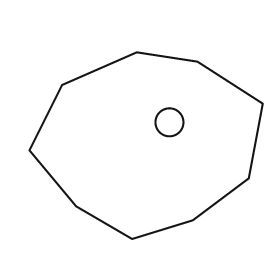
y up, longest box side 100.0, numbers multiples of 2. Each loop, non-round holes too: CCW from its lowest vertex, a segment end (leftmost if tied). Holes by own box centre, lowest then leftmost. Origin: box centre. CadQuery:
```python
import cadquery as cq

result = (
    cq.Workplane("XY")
    .moveTo(-6.0, -40.0)
    .lineTo(20.0, -32.0)
    .lineTo(44.0, -14.0)
    .lineTo(50.0, 18.0)
    .lineTo(22.0, 36.0)
    .lineTo(-4.0, 40.0)
    .lineTo(-36.0, 26.0)
    .lineTo(-50.0, -2.0)
    .lineTo(-30.0, -26.0)
    .close()
    .moveTo(10.0, 10.0)
    .circle(6.0)
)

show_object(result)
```